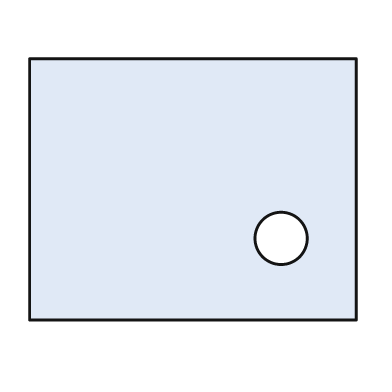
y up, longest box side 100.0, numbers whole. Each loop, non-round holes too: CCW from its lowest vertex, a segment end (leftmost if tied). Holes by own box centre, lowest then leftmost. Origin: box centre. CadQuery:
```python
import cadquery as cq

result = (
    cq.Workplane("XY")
    .moveTo(-50.0, -40.0)
    .lineTo(50.0, -40.0)
    .lineTo(50.0, 40.0)
    .lineTo(-50.0, 40.0)
    .close()
    .moveTo(27.0, -15.0)
    .circle(8.0)
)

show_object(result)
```